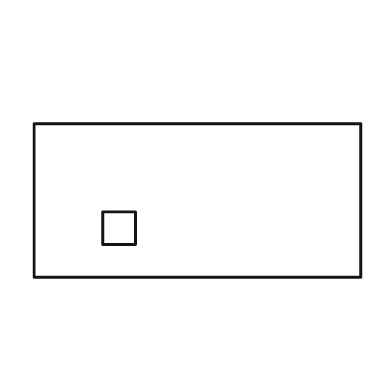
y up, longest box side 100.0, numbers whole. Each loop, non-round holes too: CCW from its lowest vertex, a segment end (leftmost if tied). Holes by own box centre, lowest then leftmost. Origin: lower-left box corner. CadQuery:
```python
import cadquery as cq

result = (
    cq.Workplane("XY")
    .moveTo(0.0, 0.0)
    .lineTo(100.0, 0.0)
    .lineTo(100.0, 47.0)
    .lineTo(0.0, 47.0)
    .close()
    .moveTo(21.0, 10.0)
    .lineTo(31.0, 10.0)
    .lineTo(31.0, 20.0)
    .lineTo(21.0, 20.0)
    .close()
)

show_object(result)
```